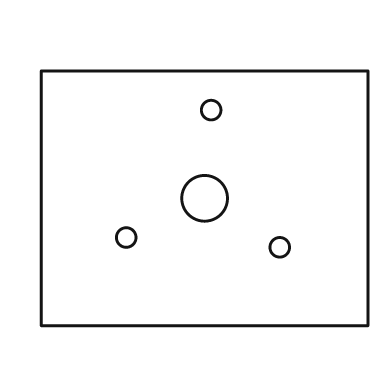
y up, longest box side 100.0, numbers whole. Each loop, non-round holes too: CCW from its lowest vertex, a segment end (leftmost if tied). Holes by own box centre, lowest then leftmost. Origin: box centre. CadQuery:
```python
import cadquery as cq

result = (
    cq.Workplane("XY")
    .moveTo(-50.0, -39.0)
    .lineTo(50.0, -39.0)
    .lineTo(50.0, 39.0)
    .lineTo(-50.0, 39.0)
    .close()
    .moveTo(23.0, -15.0)
    .circle(3.0)
    .moveTo(-24.0, -12.0)
    .circle(3.0)
    .moveTo(0.0, 0.0)
    .circle(7.0)
    .moveTo(2.0, 27.0)
    .circle(3.0)
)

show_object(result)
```